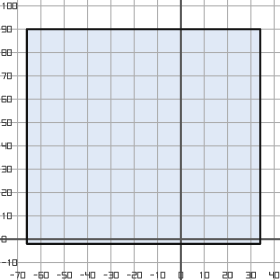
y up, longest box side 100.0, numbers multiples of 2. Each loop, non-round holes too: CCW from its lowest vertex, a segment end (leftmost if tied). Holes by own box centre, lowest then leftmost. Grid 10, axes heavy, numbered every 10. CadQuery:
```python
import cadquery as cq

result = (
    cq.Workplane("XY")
    .moveTo(-66.0, -2.0)
    .lineTo(34.0, -2.0)
    .lineTo(34.0, 90.0)
    .lineTo(-66.0, 90.0)
    .close()
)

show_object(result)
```